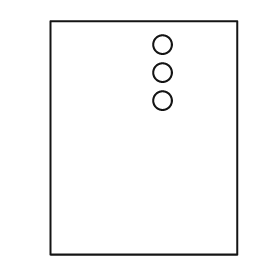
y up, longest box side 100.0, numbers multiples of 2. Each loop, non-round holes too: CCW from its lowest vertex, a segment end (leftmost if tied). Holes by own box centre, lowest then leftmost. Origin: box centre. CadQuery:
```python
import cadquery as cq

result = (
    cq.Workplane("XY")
    .moveTo(-40.0, -50.0)
    .lineTo(40.0, -50.0)
    .lineTo(40.0, 50.0)
    .lineTo(-40.0, 50.0)
    .close()
    .moveTo(8.0, 16.0)
    .circle(4.0)
    .moveTo(8.0, 28.0)
    .circle(4.0)
    .moveTo(8.0, 40.0)
    .circle(4.0)
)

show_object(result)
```